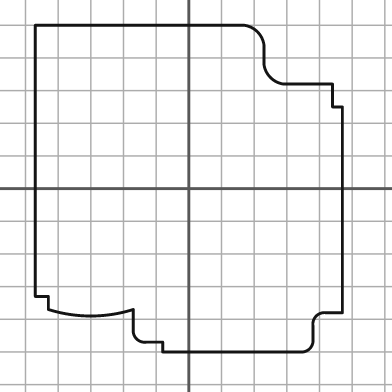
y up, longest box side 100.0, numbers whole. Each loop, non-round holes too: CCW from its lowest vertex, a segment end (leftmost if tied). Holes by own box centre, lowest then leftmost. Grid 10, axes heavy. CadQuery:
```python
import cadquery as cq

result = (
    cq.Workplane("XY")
    .moveTo(-8.0, -50.0)
    .lineTo(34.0, -50.0)
    .threePointArc((37.0, -49.0), (38.0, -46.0))
    .lineTo(38.0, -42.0)
    .threePointArc((39.0, -39.0), (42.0, -38.0))
    .lineTo(47.0, -38.0)
    .lineTo(47.0, 25.0)
    .lineTo(44.0, 25.0)
    .lineTo(44.0, 32.0)
    .lineTo(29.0, 32.0)
    .threePointArc((25.0, 34.0), (23.0, 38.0))
    .lineTo(23.0, 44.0)
    .threePointArc((21.0, 48.0), (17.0, 50.0))
    .lineTo(-47.0, 50.0)
    .lineTo(-47.0, -33.0)
    .lineTo(-43.0, -33.0)
    .lineTo(-43.0, -37.0)
    .threePointArc((-30.0, -39.0), (-17.0, -37.0))
    .lineTo(-17.0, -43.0)
    .threePointArc((-16.0, -46.0), (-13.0, -47.0))
    .lineTo(-8.0, -47.0)
    .close()
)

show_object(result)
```